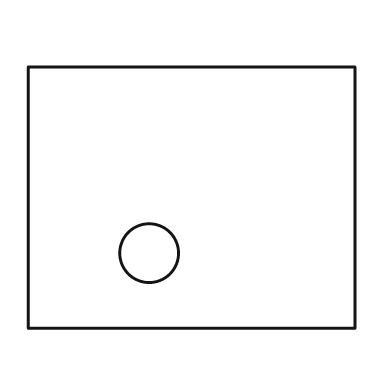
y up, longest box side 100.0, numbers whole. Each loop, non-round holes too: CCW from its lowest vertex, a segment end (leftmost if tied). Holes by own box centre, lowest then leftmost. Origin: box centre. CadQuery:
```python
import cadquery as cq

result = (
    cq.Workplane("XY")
    .moveTo(-50.0, -40.0)
    .lineTo(50.0, -40.0)
    .lineTo(50.0, 40.0)
    .lineTo(-50.0, 40.0)
    .close()
    .moveTo(-13.0, -17.0)
    .circle(9.0)
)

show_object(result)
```